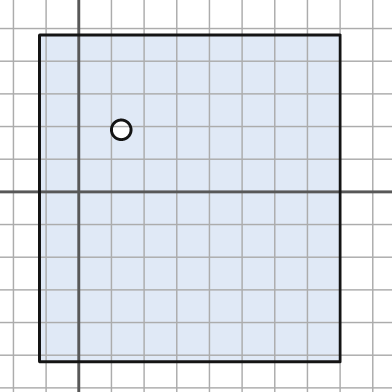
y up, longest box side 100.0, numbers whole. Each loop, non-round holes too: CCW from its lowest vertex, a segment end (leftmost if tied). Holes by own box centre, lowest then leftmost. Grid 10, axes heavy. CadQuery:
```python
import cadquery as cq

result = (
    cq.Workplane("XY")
    .moveTo(-12.0, -52.0)
    .lineTo(80.0, -52.0)
    .lineTo(80.0, 48.0)
    .lineTo(-12.0, 48.0)
    .close()
    .moveTo(13.0, 19.0)
    .circle(3.0)
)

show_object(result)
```